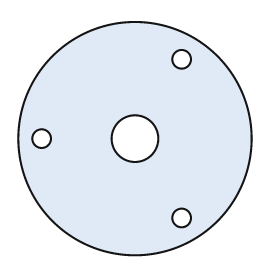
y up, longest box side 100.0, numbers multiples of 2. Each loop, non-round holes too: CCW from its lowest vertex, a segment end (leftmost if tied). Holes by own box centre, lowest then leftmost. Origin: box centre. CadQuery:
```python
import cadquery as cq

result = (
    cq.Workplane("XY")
    .moveTo(0.0, 0.0)
    .circle(50.0)
    .moveTo(20.0, -34.0)
    .circle(4.0)
    .moveTo(-40.0, 0.0)
    .circle(4.0)
    .moveTo(0.0, 0.0)
    .circle(10.0)
    .moveTo(20.0, 34.0)
    .circle(4.0)
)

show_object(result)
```